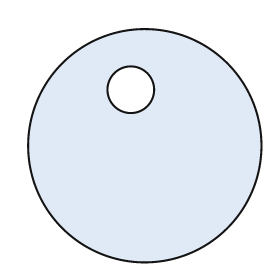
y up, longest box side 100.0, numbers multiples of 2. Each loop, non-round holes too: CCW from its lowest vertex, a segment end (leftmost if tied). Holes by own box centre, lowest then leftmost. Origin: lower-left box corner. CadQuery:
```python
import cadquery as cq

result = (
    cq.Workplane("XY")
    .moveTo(50.0, 50.0)
    .circle(50.0)
    .moveTo(44.0, 74.0)
    .circle(10.0)
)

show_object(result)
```